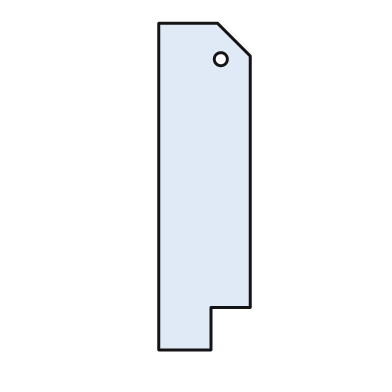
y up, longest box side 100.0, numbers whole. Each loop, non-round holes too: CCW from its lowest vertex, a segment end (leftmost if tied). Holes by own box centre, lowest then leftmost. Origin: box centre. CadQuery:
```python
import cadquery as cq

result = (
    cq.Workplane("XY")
    .moveTo(-14.0, -50.0)
    .lineTo(2.0, -50.0)
    .lineTo(2.0, -37.0)
    .lineTo(14.0, -37.0)
    .lineTo(14.0, 40.0)
    .lineTo(4.0, 50.0)
    .lineTo(-14.0, 50.0)
    .close()
    .moveTo(5.0, 39.0)
    .circle(2.0)
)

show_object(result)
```